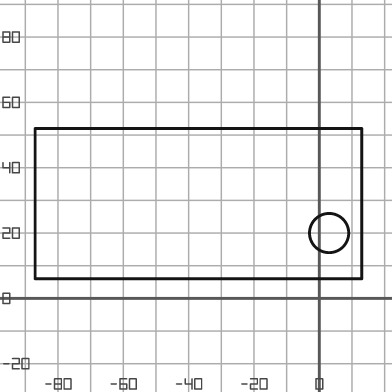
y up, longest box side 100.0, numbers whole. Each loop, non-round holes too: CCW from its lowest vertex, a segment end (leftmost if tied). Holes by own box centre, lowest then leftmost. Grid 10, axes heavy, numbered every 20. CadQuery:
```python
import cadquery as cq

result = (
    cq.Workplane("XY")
    .moveTo(-87.0, 6.0)
    .lineTo(13.0, 6.0)
    .lineTo(13.0, 52.0)
    .lineTo(-87.0, 52.0)
    .close()
    .moveTo(3.0, 20.0)
    .circle(6.0)
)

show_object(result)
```